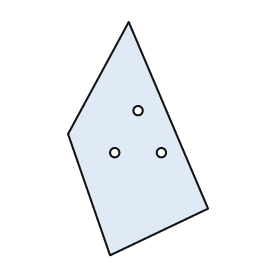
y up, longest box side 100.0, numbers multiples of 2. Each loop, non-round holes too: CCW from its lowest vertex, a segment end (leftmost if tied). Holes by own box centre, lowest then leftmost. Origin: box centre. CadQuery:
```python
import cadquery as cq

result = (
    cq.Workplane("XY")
    .moveTo(-12.0, -50.0)
    .lineTo(30.0, -30.0)
    .lineTo(-4.0, 50.0)
    .lineTo(-30.0, 2.0)
    .close()
    .moveTo(-10.0, -6.0)
    .circle(2.0)
    .moveTo(10.0, -6.0)
    .circle(2.0)
    .moveTo(0.0, 12.0)
    .circle(2.0)
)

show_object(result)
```